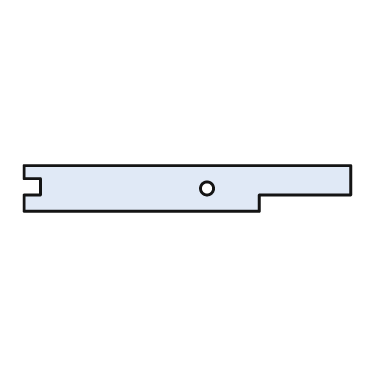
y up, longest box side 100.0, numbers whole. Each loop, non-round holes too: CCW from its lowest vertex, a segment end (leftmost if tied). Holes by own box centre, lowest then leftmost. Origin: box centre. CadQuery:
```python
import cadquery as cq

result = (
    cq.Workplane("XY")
    .moveTo(-50.0, -7.0)
    .lineTo(22.0, -7.0)
    .lineTo(22.0, -2.0)
    .lineTo(50.0, -2.0)
    .lineTo(50.0, 7.0)
    .lineTo(-50.0, 7.0)
    .lineTo(-50.0, 3.0)
    .lineTo(-45.0, 3.0)
    .lineTo(-45.0, -2.0)
    .lineTo(-50.0, -2.0)
    .close()
    .moveTo(6.0, 0.0)
    .circle(2.0)
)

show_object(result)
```